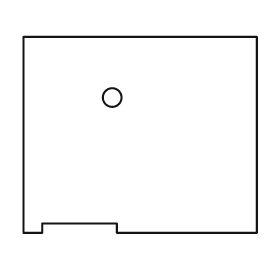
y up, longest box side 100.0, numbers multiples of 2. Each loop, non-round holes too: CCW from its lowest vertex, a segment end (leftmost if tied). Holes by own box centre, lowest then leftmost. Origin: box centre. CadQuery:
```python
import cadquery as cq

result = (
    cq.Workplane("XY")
    .moveTo(-50.0, -42.0)
    .lineTo(-42.0, -42.0)
    .lineTo(-42.0, -38.0)
    .lineTo(-10.0, -38.0)
    .lineTo(-10.0, -42.0)
    .lineTo(50.0, -42.0)
    .lineTo(50.0, 42.0)
    .lineTo(-50.0, 42.0)
    .close()
    .moveTo(-12.0, 16.0)
    .circle(4.0)
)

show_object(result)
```